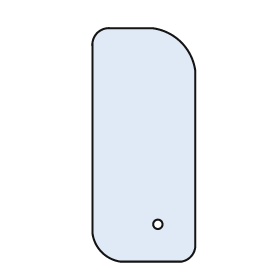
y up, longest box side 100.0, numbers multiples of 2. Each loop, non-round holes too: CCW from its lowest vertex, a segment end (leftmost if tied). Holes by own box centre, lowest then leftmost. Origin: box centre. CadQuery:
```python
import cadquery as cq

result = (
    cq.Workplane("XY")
    .moveTo(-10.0, -50.0)
    .lineTo(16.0, -50.0)
    .threePointArc((20.0, -48.0), (22.0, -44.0))
    .lineTo(22.0, 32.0)
    .threePointArc((16.0, 44.0), (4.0, 50.0))
    .lineTo(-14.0, 50.0)
    .threePointArc((-20.0, 48.0), (-22.0, 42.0))
    .lineTo(-22.0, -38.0)
    .threePointArc((-18.0, -46.0), (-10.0, -50.0))
    .close()
    .moveTo(6.0, -34.0)
    .circle(2.0)
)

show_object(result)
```